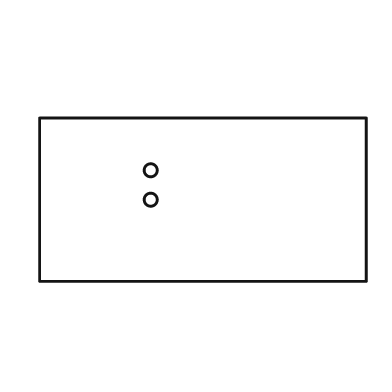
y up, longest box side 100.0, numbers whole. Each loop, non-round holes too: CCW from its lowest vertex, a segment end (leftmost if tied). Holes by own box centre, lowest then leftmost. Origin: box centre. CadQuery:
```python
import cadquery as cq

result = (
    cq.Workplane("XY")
    .moveTo(-50.0, -25.0)
    .lineTo(50.0, -25.0)
    .lineTo(50.0, 25.0)
    .lineTo(-50.0, 25.0)
    .close()
    .moveTo(-16.0, 0.0)
    .circle(2.0)
    .moveTo(-16.0, 9.0)
    .circle(2.0)
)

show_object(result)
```